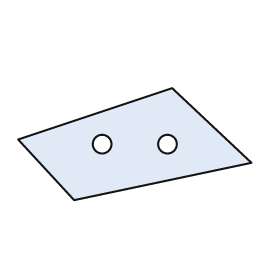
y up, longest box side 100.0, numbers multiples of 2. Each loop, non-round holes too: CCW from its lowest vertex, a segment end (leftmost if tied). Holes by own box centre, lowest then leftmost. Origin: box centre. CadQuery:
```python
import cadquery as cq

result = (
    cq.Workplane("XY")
    .moveTo(-26.0, -24.0)
    .lineTo(50.0, -8.0)
    .lineTo(16.0, 24.0)
    .lineTo(-50.0, 2.0)
    .close()
    .moveTo(-14.0, 0.0)
    .circle(4.0)
    .moveTo(14.0, 0.0)
    .circle(4.0)
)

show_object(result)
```